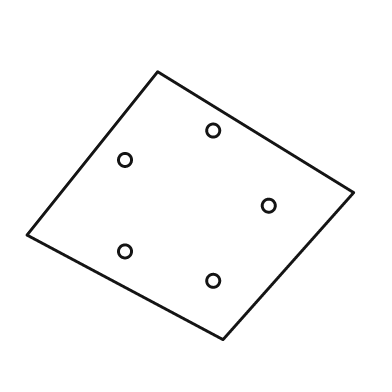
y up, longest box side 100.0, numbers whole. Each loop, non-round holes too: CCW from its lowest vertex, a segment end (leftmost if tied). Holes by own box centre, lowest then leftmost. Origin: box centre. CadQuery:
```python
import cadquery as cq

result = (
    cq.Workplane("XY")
    .moveTo(10.0, -41.0)
    .lineTo(50.0, 4.0)
    .lineTo(-10.0, 41.0)
    .lineTo(-50.0, -9.0)
    .close()
    .moveTo(7.0, -23.0)
    .circle(2.0)
    .moveTo(-20.0, -14.0)
    .circle(2.0)
    .moveTo(24.0, 0.0)
    .circle(2.0)
    .moveTo(-20.0, 14.0)
    .circle(2.0)
    .moveTo(7.0, 23.0)
    .circle(2.0)
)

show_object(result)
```